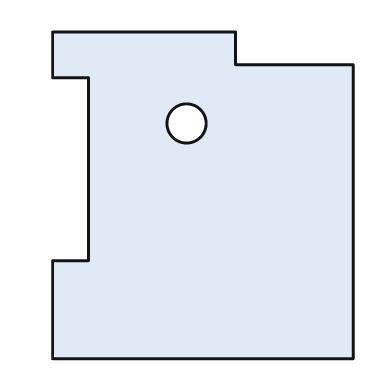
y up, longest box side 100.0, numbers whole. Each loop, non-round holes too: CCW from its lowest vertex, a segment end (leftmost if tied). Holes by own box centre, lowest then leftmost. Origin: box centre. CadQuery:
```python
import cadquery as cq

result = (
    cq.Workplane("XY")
    .moveTo(-46.0, -50.0)
    .lineTo(46.0, -50.0)
    .lineTo(46.0, 40.0)
    .lineTo(10.0, 40.0)
    .lineTo(10.0, 50.0)
    .lineTo(-46.0, 50.0)
    .lineTo(-46.0, 36.0)
    .lineTo(-35.0, 36.0)
    .lineTo(-35.0, -20.0)
    .lineTo(-46.0, -20.0)
    .close()
    .moveTo(-5.0, 22.0)
    .circle(6.0)
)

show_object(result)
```